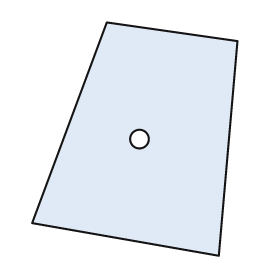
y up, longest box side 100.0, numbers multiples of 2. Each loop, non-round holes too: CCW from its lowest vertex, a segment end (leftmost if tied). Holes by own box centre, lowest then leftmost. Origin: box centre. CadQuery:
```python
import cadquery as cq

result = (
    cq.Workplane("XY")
    .moveTo(36.0, -50.0)
    .lineTo(44.0, 42.0)
    .lineTo(-12.0, 50.0)
    .lineTo(-44.0, -36.0)
    .close()
    .moveTo(2.0, 0.0)
    .circle(4.0)
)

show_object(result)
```